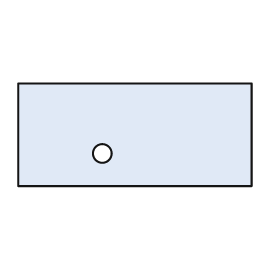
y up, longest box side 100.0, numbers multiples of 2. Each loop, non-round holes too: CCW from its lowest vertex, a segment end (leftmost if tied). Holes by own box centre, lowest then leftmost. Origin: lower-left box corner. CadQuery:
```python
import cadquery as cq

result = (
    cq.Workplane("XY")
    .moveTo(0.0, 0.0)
    .lineTo(100.0, 0.0)
    .lineTo(100.0, 44.0)
    .lineTo(0.0, 44.0)
    .close()
    .moveTo(36.0, 14.0)
    .circle(4.0)
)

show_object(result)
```